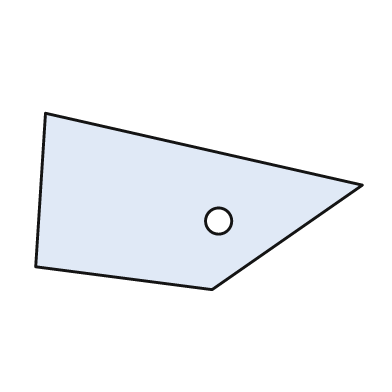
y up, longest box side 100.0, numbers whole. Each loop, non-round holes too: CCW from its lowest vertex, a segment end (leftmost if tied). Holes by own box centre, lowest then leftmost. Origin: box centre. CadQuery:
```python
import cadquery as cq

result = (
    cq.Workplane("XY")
    .moveTo(4.0, -27.0)
    .lineTo(50.0, 5.0)
    .lineTo(-47.0, 27.0)
    .lineTo(-50.0, -20.0)
    .close()
    .moveTo(6.0, -6.0)
    .circle(4.0)
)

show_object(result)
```